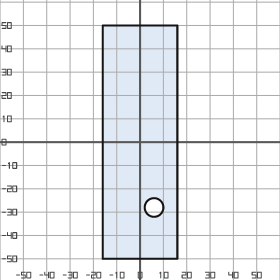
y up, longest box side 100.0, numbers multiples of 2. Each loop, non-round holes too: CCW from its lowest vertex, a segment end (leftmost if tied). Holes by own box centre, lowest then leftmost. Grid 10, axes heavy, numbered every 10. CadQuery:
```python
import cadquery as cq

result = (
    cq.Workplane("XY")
    .moveTo(-16.0, -50.0)
    .lineTo(16.0, -50.0)
    .lineTo(16.0, 50.0)
    .lineTo(-16.0, 50.0)
    .close()
    .moveTo(6.0, -28.0)
    .circle(4.0)
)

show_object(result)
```